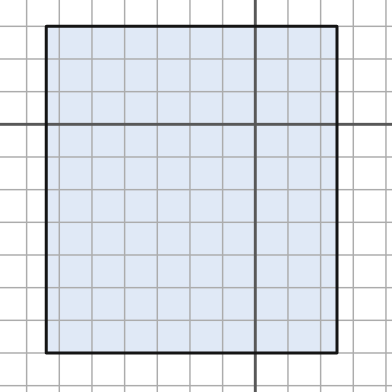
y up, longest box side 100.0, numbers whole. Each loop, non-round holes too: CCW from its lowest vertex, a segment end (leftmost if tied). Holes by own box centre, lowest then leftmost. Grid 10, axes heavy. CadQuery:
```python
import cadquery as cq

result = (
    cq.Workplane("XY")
    .moveTo(-64.0, -70.0)
    .lineTo(25.0, -70.0)
    .lineTo(25.0, 30.0)
    .lineTo(-64.0, 30.0)
    .close()
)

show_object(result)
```